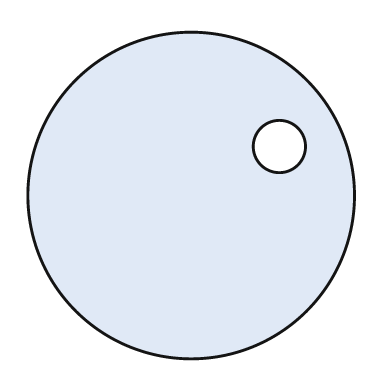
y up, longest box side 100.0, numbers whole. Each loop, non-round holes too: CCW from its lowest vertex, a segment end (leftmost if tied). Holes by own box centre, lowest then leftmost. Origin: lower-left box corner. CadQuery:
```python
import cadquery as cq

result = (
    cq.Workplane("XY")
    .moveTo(50.0, 50.0)
    .circle(50.0)
    .moveTo(77.0, 65.0)
    .circle(8.0)
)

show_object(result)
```